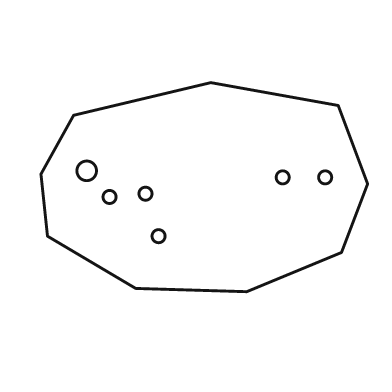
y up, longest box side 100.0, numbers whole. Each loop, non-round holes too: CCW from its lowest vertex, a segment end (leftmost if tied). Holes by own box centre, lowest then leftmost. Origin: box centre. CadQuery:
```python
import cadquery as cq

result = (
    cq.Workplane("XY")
    .moveTo(13.0, -32.0)
    .lineTo(42.0, -20.0)
    .lineTo(50.0, 1.0)
    .lineTo(41.0, 25.0)
    .lineTo(2.0, 32.0)
    .lineTo(-40.0, 22.0)
    .lineTo(-50.0, 4.0)
    .lineTo(-48.0, -15.0)
    .lineTo(-21.0, -31.0)
    .close()
    .moveTo(-14.0, -15.0)
    .circle(2.0)
    .moveTo(-29.0, -3.0)
    .circle(2.0)
    .moveTo(-18.0, -2.0)
    .circle(2.0)
    .moveTo(24.0, 3.0)
    .circle(2.0)
    .moveTo(37.0, 3.0)
    .circle(2.0)
    .moveTo(-36.0, 5.0)
    .circle(3.0)
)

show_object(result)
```